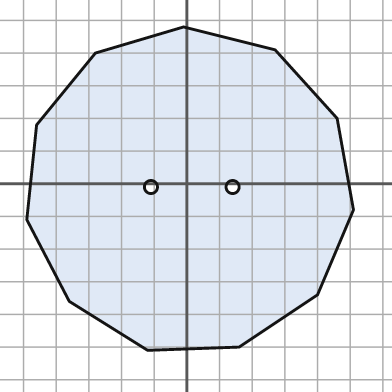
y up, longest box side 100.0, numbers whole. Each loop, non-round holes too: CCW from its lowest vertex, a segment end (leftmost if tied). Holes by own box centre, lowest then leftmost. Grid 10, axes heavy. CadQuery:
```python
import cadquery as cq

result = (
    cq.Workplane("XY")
    .moveTo(-12.0, -51.0)
    .lineTo(16.0, -50.0)
    .lineTo(40.0, -34.0)
    .lineTo(51.0, -8.0)
    .lineTo(46.0, 20.0)
    .lineTo(27.0, 41.0)
    .lineTo(-1.0, 48.0)
    .lineTo(-28.0, 40.0)
    .lineTo(-46.0, 18.0)
    .lineTo(-49.0, -11.0)
    .lineTo(-36.0, -36.0)
    .close()
    .moveTo(-11.0, -1.0)
    .circle(2.0)
    .moveTo(14.0, -1.0)
    .circle(2.0)
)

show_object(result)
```